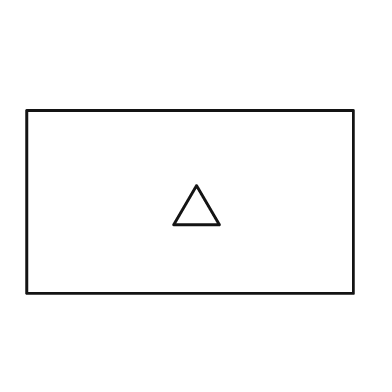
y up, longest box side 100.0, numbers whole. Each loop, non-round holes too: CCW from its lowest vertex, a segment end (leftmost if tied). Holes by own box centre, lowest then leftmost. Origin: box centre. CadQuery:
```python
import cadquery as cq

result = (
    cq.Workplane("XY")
    .moveTo(-50.0, -28.0)
    .lineTo(50.0, -28.0)
    .lineTo(50.0, 28.0)
    .lineTo(-50.0, 28.0)
    .close()
    .moveTo(-5.0, -7.0)
    .lineTo(9.0, -7.0)
    .lineTo(2.0, 5.0)
    .close()
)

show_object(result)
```